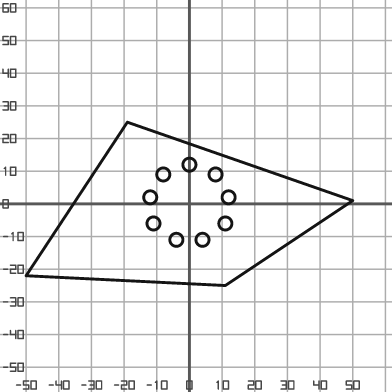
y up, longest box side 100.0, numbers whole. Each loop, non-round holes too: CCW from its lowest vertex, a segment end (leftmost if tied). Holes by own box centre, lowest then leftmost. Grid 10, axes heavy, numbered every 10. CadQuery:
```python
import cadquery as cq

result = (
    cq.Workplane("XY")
    .moveTo(11.0, -25.0)
    .lineTo(50.0, 1.0)
    .lineTo(-19.0, 25.0)
    .lineTo(-50.0, -22.0)
    .close()
    .moveTo(-4.0, -11.0)
    .circle(2.0)
    .moveTo(4.0, -11.0)
    .circle(2.0)
    .moveTo(-11.0, -6.0)
    .circle(2.0)
    .moveTo(11.0, -6.0)
    .circle(2.0)
    .moveTo(-12.0, 2.0)
    .circle(2.0)
    .moveTo(12.0, 2.0)
    .circle(2.0)
    .moveTo(-8.0, 9.0)
    .circle(2.0)
    .moveTo(8.0, 9.0)
    .circle(2.0)
    .moveTo(0.0, 12.0)
    .circle(2.0)
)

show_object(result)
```